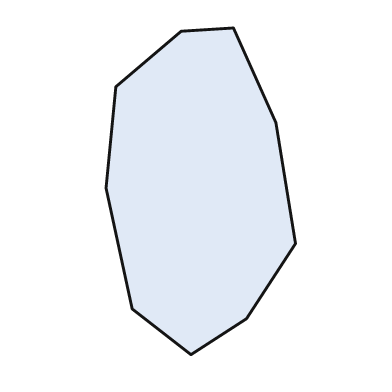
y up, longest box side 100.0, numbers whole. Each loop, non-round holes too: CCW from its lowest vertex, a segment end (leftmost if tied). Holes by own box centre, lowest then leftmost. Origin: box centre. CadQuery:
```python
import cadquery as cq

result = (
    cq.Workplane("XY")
    .moveTo(-3.0, -50.0)
    .lineTo(14.0, -39.0)
    .lineTo(29.0, -16.0)
    .lineTo(23.0, 21.0)
    .lineTo(10.0, 50.0)
    .lineTo(-6.0, 49.0)
    .lineTo(-26.0, 32.0)
    .lineTo(-29.0, 1.0)
    .lineTo(-21.0, -36.0)
    .close()
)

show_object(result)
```